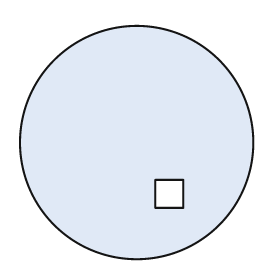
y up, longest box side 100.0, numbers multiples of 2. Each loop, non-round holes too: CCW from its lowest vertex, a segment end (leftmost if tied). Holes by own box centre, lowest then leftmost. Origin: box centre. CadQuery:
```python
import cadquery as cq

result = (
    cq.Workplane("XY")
    .moveTo(0.0, 0.0)
    .circle(50.0)
    .moveTo(8.0, -28.0)
    .lineTo(20.0, -28.0)
    .lineTo(20.0, -16.0)
    .lineTo(8.0, -16.0)
    .close()
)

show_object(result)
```